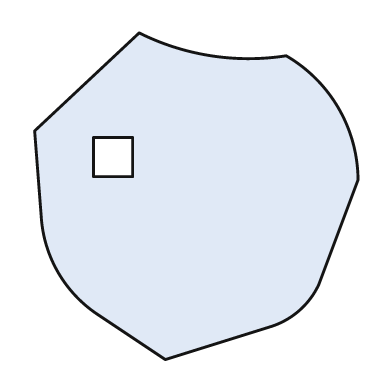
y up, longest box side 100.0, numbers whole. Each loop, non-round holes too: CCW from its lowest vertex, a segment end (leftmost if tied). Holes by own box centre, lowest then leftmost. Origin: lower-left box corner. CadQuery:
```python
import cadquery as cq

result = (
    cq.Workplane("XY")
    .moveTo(40.0, 0.0)
    .lineTo(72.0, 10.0)
    .threePointArc((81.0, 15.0), (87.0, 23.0))
    .lineTo(99.0, 55.0)
    .threePointArc((93.0, 77.0), (77.0, 93.0))
    .threePointArc((54.0, 93.0), (32.0, 100.0))
    .lineTo(0.0, 70.0)
    .lineTo(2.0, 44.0)
    .threePointArc((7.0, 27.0), (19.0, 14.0))
    .close()
    .moveTo(18.0, 56.0)
    .lineTo(30.0, 56.0)
    .lineTo(30.0, 68.0)
    .lineTo(18.0, 68.0)
    .close()
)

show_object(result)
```